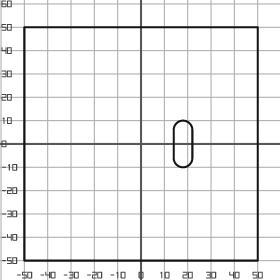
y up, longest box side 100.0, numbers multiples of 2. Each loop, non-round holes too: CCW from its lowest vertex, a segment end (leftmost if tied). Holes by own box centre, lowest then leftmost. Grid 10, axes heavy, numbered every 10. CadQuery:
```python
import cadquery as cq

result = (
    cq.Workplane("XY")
    .moveTo(-50.0, -50.0)
    .lineTo(50.0, -50.0)
    .lineTo(50.0, 50.0)
    .lineTo(-50.0, 50.0)
    .close()
    .moveTo(14.0, -6.0)
    .threePointArc((18.0, -10.0), (22.0, -6.0))
    .lineTo(22.0, 6.0)
    .threePointArc((18.0, 10.0), (14.0, 6.0))
    .close()
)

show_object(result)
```